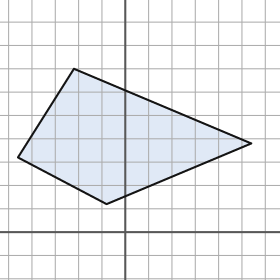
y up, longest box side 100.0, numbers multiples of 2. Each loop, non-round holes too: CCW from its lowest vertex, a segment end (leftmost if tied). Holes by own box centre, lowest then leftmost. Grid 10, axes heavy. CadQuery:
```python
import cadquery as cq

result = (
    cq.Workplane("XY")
    .moveTo(-8.0, 12.0)
    .lineTo(54.0, 38.0)
    .lineTo(-22.0, 70.0)
    .lineTo(-46.0, 32.0)
    .close()
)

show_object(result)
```